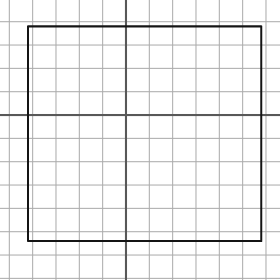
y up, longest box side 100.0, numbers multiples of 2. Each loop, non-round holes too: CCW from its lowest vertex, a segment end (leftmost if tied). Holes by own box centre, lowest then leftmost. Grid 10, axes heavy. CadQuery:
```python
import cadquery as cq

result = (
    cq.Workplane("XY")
    .moveTo(-42.0, -54.0)
    .lineTo(58.0, -54.0)
    .lineTo(58.0, 38.0)
    .lineTo(-42.0, 38.0)
    .close()
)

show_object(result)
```